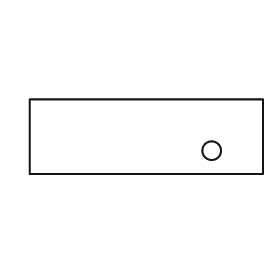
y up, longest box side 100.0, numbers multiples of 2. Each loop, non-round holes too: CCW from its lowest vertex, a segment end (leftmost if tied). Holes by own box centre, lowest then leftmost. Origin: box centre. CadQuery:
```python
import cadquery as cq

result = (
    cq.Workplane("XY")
    .moveTo(-50.0, -16.0)
    .lineTo(50.0, -16.0)
    .lineTo(50.0, 16.0)
    .lineTo(-50.0, 16.0)
    .close()
    .moveTo(28.0, -6.0)
    .circle(4.0)
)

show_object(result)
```